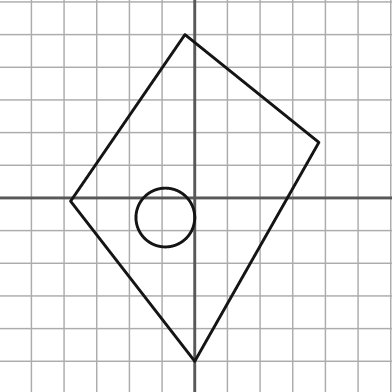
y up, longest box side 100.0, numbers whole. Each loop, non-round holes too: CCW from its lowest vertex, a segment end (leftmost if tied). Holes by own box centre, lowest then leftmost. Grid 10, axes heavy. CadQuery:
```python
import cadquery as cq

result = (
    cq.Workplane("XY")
    .moveTo(0.0, -50.0)
    .lineTo(38.0, 17.0)
    .lineTo(-3.0, 50.0)
    .lineTo(-38.0, -1.0)
    .close()
    .moveTo(-9.0, -6.0)
    .circle(9.0)
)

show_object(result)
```